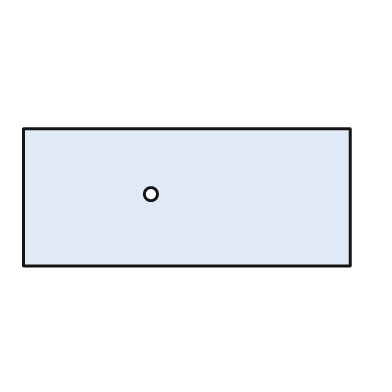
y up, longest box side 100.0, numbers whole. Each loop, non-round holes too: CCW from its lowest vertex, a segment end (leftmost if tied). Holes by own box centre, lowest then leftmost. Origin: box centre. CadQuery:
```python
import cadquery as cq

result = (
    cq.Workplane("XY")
    .moveTo(-50.0, -21.0)
    .lineTo(50.0, -21.0)
    .lineTo(50.0, 21.0)
    .lineTo(-50.0, 21.0)
    .close()
    .moveTo(-11.0, 1.0)
    .circle(2.0)
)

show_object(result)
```